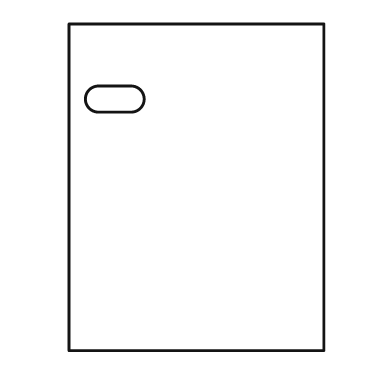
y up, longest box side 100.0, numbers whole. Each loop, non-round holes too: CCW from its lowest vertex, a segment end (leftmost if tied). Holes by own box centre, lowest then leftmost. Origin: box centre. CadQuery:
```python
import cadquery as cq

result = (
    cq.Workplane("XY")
    .moveTo(-39.0, -50.0)
    .lineTo(39.0, -50.0)
    .lineTo(39.0, 50.0)
    .lineTo(-39.0, 50.0)
    .close()
    .moveTo(-30.0, 23.0)
    .lineTo(-20.0, 23.0)
    .threePointArc((-16.0, 27.0), (-20.0, 31.0))
    .lineTo(-30.0, 31.0)
    .threePointArc((-34.0, 27.0), (-30.0, 23.0))
    .close()
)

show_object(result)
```